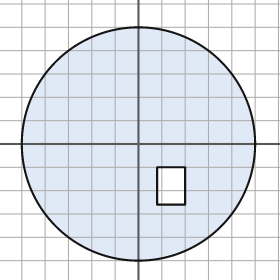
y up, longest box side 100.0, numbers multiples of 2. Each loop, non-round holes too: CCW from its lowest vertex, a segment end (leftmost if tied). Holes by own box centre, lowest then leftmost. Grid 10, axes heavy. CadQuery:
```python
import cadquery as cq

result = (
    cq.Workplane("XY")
    .moveTo(0.0, 0.0)
    .circle(50.0)
    .moveTo(8.0, -26.0)
    .lineTo(20.0, -26.0)
    .lineTo(20.0, -10.0)
    .lineTo(8.0, -10.0)
    .close()
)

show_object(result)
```